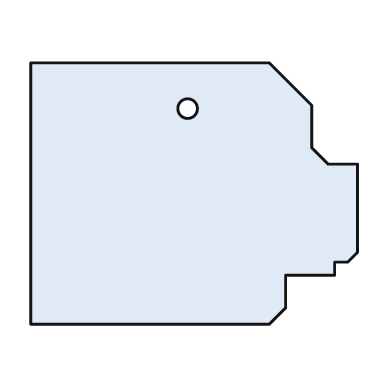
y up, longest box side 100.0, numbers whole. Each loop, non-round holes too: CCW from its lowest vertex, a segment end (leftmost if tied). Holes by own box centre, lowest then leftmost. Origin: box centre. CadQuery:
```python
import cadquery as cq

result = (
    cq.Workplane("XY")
    .moveTo(-50.0, -40.0)
    .lineTo(23.0, -40.0)
    .lineTo(28.0, -35.0)
    .lineTo(28.0, -25.0)
    .lineTo(43.0, -25.0)
    .lineTo(43.0, -21.0)
    .lineTo(47.0, -21.0)
    .lineTo(50.0, -18.0)
    .lineTo(50.0, 9.0)
    .lineTo(41.0, 9.0)
    .lineTo(36.0, 14.0)
    .lineTo(36.0, 27.0)
    .lineTo(23.0, 40.0)
    .lineTo(-50.0, 40.0)
    .close()
    .moveTo(-2.0, 26.0)
    .circle(3.0)
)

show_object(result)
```